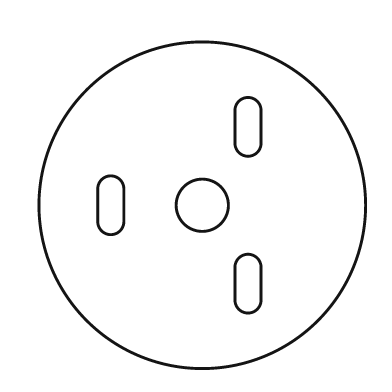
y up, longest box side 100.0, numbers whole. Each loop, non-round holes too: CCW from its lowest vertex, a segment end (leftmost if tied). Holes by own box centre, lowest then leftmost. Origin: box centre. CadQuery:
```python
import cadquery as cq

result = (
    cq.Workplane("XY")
    .moveTo(0.0, 0.0)
    .circle(50.0)
    .moveTo(10.0, -29.0)
    .threePointArc((14.0, -33.0), (18.0, -29.0))
    .lineTo(18.0, -19.0)
    .threePointArc((14.0, -15.0), (10.0, -19.0))
    .close()
    .moveTo(-32.0, -5.0)
    .threePointArc((-28.0, -9.0), (-24.0, -5.0))
    .lineTo(-24.0, 5.0)
    .threePointArc((-28.0, 9.0), (-32.0, 5.0))
    .close()
    .moveTo(0.0, 0.0)
    .circle(8.0)
    .moveTo(10.0, 19.0)
    .threePointArc((14.0, 15.0), (18.0, 19.0))
    .lineTo(18.0, 29.0)
    .threePointArc((14.0, 33.0), (10.0, 29.0))
    .close()
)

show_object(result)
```